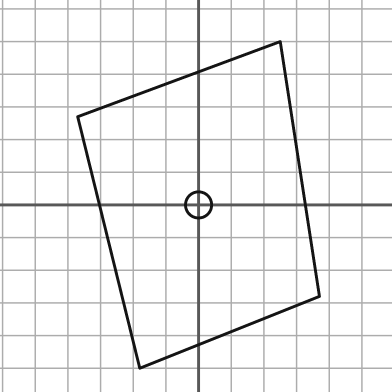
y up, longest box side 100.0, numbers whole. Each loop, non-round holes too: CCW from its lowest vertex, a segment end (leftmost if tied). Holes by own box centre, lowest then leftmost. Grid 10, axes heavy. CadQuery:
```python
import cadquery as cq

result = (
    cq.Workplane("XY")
    .moveTo(-18.0, -50.0)
    .lineTo(37.0, -28.0)
    .lineTo(25.0, 50.0)
    .lineTo(-37.0, 27.0)
    .close()
    .moveTo(0.0, 0.0)
    .circle(4.0)
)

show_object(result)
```